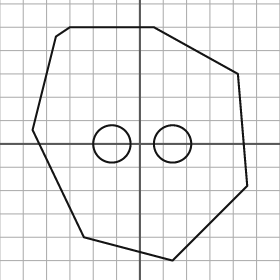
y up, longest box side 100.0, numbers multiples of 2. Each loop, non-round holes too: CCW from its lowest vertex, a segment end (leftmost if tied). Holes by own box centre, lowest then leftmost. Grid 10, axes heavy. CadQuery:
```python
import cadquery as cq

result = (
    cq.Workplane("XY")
    .moveTo(14.0, -50.0)
    .lineTo(46.0, -18.0)
    .lineTo(42.0, 30.0)
    .lineTo(6.0, 50.0)
    .lineTo(-30.0, 50.0)
    .lineTo(-36.0, 46.0)
    .lineTo(-46.0, 6.0)
    .lineTo(-24.0, -40.0)
    .close()
    .moveTo(-12.0, 0.0)
    .circle(8.0)
    .moveTo(14.0, 0.0)
    .circle(8.0)
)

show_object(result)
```